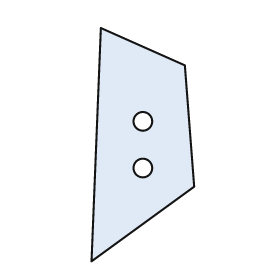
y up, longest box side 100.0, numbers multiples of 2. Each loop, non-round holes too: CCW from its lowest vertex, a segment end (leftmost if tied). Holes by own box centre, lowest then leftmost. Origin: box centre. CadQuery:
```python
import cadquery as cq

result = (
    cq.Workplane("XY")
    .moveTo(-22.0, -50.0)
    .lineTo(22.0, -18.0)
    .lineTo(18.0, 34.0)
    .lineTo(-18.0, 50.0)
    .close()
    .moveTo(0.0, -10.0)
    .circle(4.0)
    .moveTo(0.0, 10.0)
    .circle(4.0)
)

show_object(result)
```